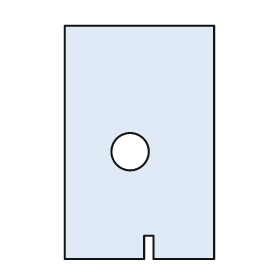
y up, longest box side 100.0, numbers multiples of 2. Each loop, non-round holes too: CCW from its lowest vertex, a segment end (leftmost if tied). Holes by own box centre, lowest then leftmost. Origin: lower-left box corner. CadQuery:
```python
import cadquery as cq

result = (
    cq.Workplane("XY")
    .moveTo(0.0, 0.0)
    .lineTo(34.0, 0.0)
    .lineTo(34.0, 10.0)
    .lineTo(38.0, 10.0)
    .lineTo(38.0, 0.0)
    .lineTo(64.0, 0.0)
    .lineTo(64.0, 100.0)
    .lineTo(0.0, 100.0)
    .close()
    .moveTo(28.0, 46.0)
    .circle(8.0)
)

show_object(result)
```